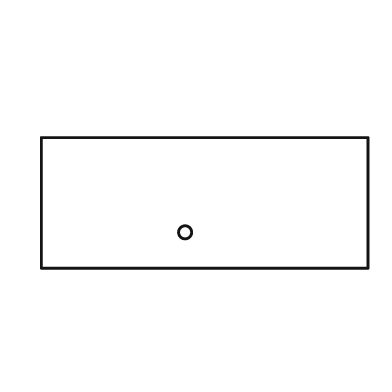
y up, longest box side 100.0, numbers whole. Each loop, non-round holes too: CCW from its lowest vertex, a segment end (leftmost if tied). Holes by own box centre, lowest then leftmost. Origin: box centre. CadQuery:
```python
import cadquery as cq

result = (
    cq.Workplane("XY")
    .moveTo(-50.0, -20.0)
    .lineTo(50.0, -20.0)
    .lineTo(50.0, 20.0)
    .lineTo(-50.0, 20.0)
    .close()
    .moveTo(-6.0, -9.0)
    .circle(2.0)
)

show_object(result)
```